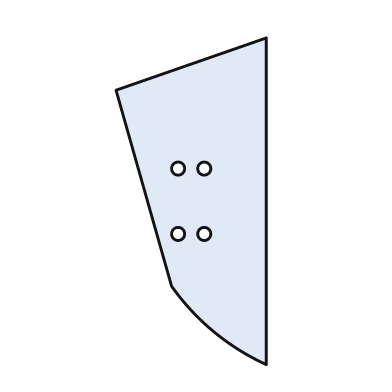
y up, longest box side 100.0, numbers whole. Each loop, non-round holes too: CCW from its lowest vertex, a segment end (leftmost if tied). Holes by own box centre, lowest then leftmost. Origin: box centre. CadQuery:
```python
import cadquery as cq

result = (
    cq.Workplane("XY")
    .moveTo(23.0, -50.0)
    .lineTo(23.0, 50.0)
    .lineTo(-23.0, 34.0)
    .lineTo(-6.0, -26.0)
    .threePointArc((7.0, -40.0), (23.0, -50.0))
    .close()
    .moveTo(-4.0, -10.0)
    .circle(2.0)
    .moveTo(4.0, -10.0)
    .circle(2.0)
    .moveTo(-4.0, 10.0)
    .circle(2.0)
    .moveTo(4.0, 10.0)
    .circle(2.0)
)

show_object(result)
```